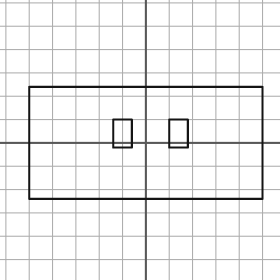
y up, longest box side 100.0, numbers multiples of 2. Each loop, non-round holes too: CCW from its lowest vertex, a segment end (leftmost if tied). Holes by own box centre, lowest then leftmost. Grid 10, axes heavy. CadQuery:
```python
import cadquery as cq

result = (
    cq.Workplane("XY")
    .moveTo(-50.0, -24.0)
    .lineTo(50.0, -24.0)
    .lineTo(50.0, 24.0)
    .lineTo(-50.0, 24.0)
    .close()
    .moveTo(-14.0, -2.0)
    .lineTo(-6.0, -2.0)
    .lineTo(-6.0, 10.0)
    .lineTo(-14.0, 10.0)
    .close()
    .moveTo(10.0, -2.0)
    .lineTo(18.0, -2.0)
    .lineTo(18.0, 10.0)
    .lineTo(10.0, 10.0)
    .close()
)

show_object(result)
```